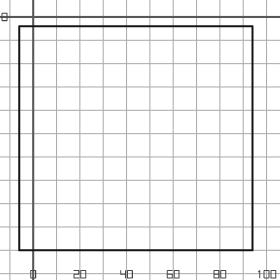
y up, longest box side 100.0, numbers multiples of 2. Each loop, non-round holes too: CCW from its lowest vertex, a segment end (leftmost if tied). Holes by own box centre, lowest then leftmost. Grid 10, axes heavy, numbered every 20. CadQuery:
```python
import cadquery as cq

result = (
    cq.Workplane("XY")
    .moveTo(-6.0, -100.0)
    .lineTo(94.0, -100.0)
    .lineTo(94.0, -4.0)
    .lineTo(-6.0, -4.0)
    .close()
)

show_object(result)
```